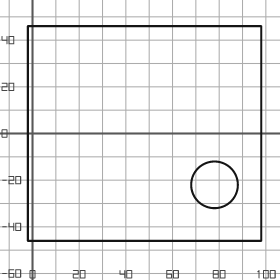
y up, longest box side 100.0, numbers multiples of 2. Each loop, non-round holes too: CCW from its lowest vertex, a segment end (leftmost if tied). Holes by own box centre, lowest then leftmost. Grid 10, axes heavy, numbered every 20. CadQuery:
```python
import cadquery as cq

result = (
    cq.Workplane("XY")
    .moveTo(-2.0, -46.0)
    .lineTo(98.0, -46.0)
    .lineTo(98.0, 46.0)
    .lineTo(-2.0, 46.0)
    .close()
    .moveTo(78.0, -22.0)
    .circle(10.0)
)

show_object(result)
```